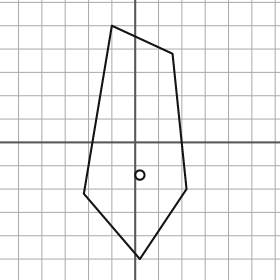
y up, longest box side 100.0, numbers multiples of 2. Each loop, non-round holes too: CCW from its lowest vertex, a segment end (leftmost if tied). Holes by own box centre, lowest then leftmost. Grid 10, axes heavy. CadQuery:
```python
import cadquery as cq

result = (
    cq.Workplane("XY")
    .moveTo(2.0, -50.0)
    .lineTo(22.0, -20.0)
    .lineTo(16.0, 38.0)
    .lineTo(-10.0, 50.0)
    .lineTo(-22.0, -22.0)
    .close()
    .moveTo(2.0, -14.0)
    .circle(2.0)
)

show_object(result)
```